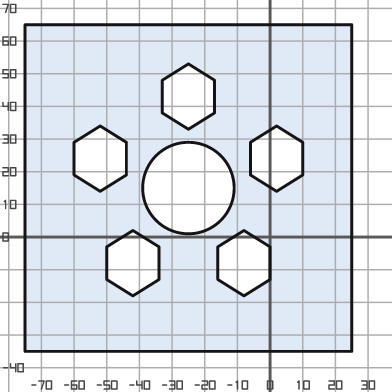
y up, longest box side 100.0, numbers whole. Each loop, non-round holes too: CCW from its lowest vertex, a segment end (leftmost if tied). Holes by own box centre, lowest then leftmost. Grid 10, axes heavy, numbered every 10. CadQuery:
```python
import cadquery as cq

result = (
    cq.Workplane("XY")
    .moveTo(-75.0, -35.0)
    .lineTo(25.0, -35.0)
    .lineTo(25.0, 65.0)
    .lineTo(-75.0, 65.0)
    .close()
    .moveTo(-42.0, -18.0)
    .lineTo(-34.0, -13.0)
    .lineTo(-34.0, -3.0)
    .lineTo(-42.0, 2.0)
    .lineTo(-50.0, -3.0)
    .lineTo(-50.0, -13.0)
    .close()
    .moveTo(-8.0, -18.0)
    .lineTo(0.0, -13.0)
    .lineTo(0.0, -3.0)
    .lineTo(-8.0, 2.0)
    .lineTo(-16.0, -3.0)
    .lineTo(-16.0, -13.0)
    .close()
    .moveTo(-25.0, 15.0)
    .circle(14.0)
    .moveTo(-52.0, 14.0)
    .lineTo(-44.0, 19.0)
    .lineTo(-44.0, 29.0)
    .lineTo(-52.0, 34.0)
    .lineTo(-60.0, 29.0)
    .lineTo(-60.0, 19.0)
    .close()
    .moveTo(2.0, 14.0)
    .lineTo(10.0, 19.0)
    .lineTo(10.0, 29.0)
    .lineTo(2.0, 34.0)
    .lineTo(-6.0, 29.0)
    .lineTo(-6.0, 19.0)
    .close()
    .moveTo(-25.0, 33.0)
    .lineTo(-17.0, 38.0)
    .lineTo(-17.0, 48.0)
    .lineTo(-25.0, 53.0)
    .lineTo(-33.0, 48.0)
    .lineTo(-33.0, 38.0)
    .close()
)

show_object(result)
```